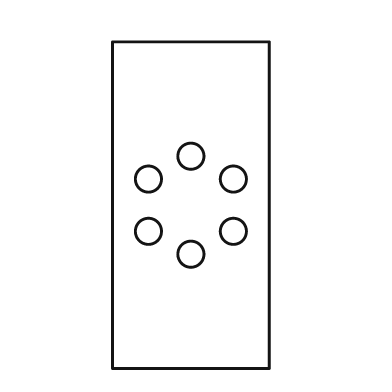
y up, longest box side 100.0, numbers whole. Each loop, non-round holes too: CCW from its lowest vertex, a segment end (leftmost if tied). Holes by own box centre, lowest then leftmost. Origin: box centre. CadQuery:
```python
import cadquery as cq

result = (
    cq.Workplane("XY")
    .moveTo(-24.0, -50.0)
    .lineTo(24.0, -50.0)
    .lineTo(24.0, 50.0)
    .lineTo(-24.0, 50.0)
    .close()
    .moveTo(0.0, -15.0)
    .circle(4.0)
    .moveTo(-13.0, -8.0)
    .circle(4.0)
    .moveTo(13.0, -8.0)
    .circle(4.0)
    .moveTo(-13.0, 8.0)
    .circle(4.0)
    .moveTo(13.0, 8.0)
    .circle(4.0)
    .moveTo(0.0, 15.0)
    .circle(4.0)
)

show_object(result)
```